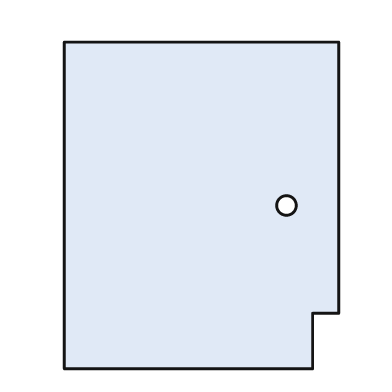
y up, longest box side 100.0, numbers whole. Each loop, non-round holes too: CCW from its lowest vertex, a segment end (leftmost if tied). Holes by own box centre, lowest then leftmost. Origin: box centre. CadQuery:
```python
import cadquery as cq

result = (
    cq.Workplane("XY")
    .moveTo(-42.0, -50.0)
    .lineTo(34.0, -50.0)
    .lineTo(34.0, -33.0)
    .lineTo(42.0, -33.0)
    .lineTo(42.0, 50.0)
    .lineTo(-42.0, 50.0)
    .close()
    .moveTo(26.0, 0.0)
    .circle(3.0)
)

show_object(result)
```